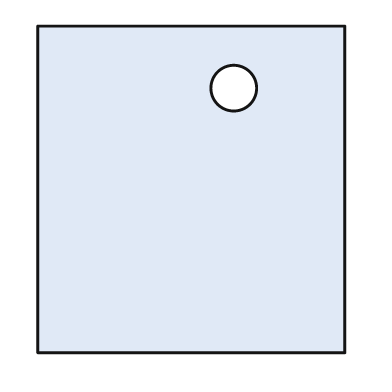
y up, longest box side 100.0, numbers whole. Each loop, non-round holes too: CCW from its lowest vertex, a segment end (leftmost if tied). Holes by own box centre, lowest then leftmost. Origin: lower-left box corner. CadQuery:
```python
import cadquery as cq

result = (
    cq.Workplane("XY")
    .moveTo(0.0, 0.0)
    .lineTo(94.0, 0.0)
    .lineTo(94.0, 100.0)
    .lineTo(0.0, 100.0)
    .close()
    .moveTo(60.0, 81.0)
    .circle(7.0)
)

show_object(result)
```